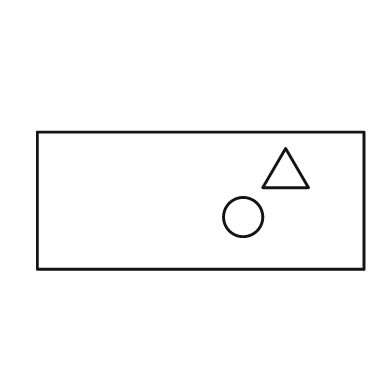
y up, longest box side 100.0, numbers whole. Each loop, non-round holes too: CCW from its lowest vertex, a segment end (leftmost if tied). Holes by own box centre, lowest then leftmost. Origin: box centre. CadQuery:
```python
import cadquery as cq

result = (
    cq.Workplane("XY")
    .moveTo(-50.0, -21.0)
    .lineTo(50.0, -21.0)
    .lineTo(50.0, 21.0)
    .lineTo(-50.0, 21.0)
    .close()
    .moveTo(13.0, -5.0)
    .circle(6.0)
    .moveTo(19.0, 4.0)
    .lineTo(33.0, 4.0)
    .lineTo(26.0, 16.0)
    .close()
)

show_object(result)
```